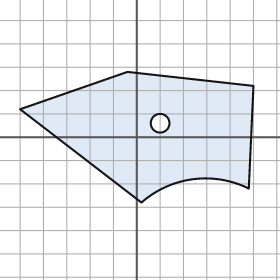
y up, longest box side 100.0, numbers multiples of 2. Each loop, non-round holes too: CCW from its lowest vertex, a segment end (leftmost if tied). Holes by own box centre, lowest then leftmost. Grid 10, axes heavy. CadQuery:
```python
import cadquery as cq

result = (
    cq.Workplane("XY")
    .moveTo(2.0, -28.0)
    .threePointArc((24.0, -18.0), (48.0, -22.0))
    .lineTo(50.0, 22.0)
    .lineTo(-4.0, 28.0)
    .lineTo(-50.0, 12.0)
    .close()
    .moveTo(10.0, 6.0)
    .circle(4.0)
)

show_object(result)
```